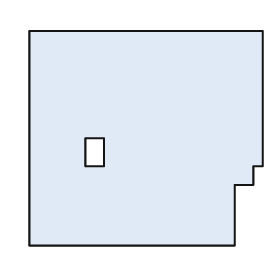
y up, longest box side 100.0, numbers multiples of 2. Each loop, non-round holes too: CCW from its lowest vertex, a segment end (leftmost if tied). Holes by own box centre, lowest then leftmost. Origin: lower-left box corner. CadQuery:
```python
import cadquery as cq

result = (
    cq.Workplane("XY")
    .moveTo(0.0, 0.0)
    .lineTo(88.0, 0.0)
    .lineTo(88.0, 26.0)
    .lineTo(96.0, 26.0)
    .lineTo(96.0, 34.0)
    .lineTo(100.0, 34.0)
    .lineTo(100.0, 92.0)
    .lineTo(0.0, 92.0)
    .close()
    .moveTo(24.0, 34.0)
    .lineTo(32.0, 34.0)
    .lineTo(32.0, 46.0)
    .lineTo(24.0, 46.0)
    .close()
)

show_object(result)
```